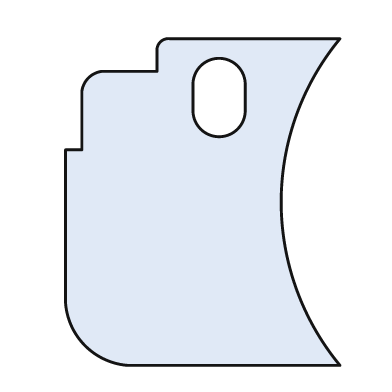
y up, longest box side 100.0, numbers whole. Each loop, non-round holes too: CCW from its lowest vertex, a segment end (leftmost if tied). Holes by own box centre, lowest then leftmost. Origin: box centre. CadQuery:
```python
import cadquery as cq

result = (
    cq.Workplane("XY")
    .moveTo(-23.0, -50.0)
    .lineTo(42.0, -50.0)
    .threePointArc((24.0, 0.0), (42.0, 50.0))
    .lineTo(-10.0, 50.0)
    .threePointArc((-13.0, 49.0), (-14.0, 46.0))
    .lineTo(-14.0, 40.0)
    .lineTo(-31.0, 40.0)
    .threePointArc((-35.0, 38.0), (-37.0, 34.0))
    .lineTo(-37.0, 16.0)
    .lineTo(-42.0, 16.0)
    .lineTo(-42.0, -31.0)
    .threePointArc((-36.0, -44.0), (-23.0, -50.0))
    .close()
    .moveTo(-3.0, 28.0)
    .threePointArc((5.0, 20.0), (13.0, 28.0))
    .lineTo(13.0, 36.0)
    .threePointArc((5.0, 44.0), (-3.0, 36.0))
    .close()
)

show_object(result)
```